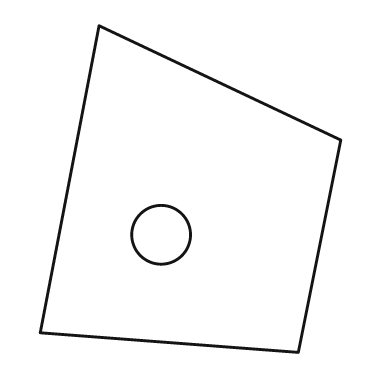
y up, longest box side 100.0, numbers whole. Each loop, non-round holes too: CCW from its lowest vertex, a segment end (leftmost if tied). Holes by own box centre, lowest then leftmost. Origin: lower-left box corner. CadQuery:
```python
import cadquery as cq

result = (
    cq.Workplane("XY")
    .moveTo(79.0, 0.0)
    .lineTo(92.0, 65.0)
    .lineTo(18.0, 100.0)
    .lineTo(0.0, 6.0)
    .close()
    .moveTo(37.0, 36.0)
    .circle(9.0)
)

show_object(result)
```